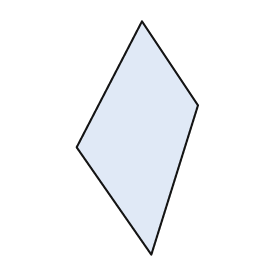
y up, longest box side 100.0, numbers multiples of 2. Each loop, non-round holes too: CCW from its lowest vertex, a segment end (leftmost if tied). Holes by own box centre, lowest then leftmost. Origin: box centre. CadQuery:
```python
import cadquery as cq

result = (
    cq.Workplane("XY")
    .moveTo(6.0, -50.0)
    .lineTo(26.0, 14.0)
    .lineTo(2.0, 50.0)
    .lineTo(-26.0, -4.0)
    .close()
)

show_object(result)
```